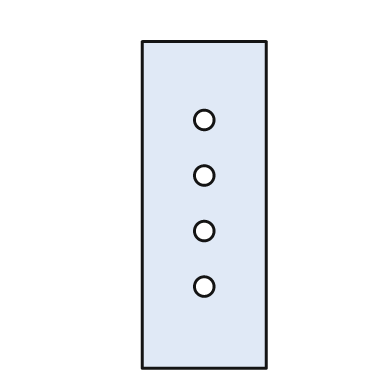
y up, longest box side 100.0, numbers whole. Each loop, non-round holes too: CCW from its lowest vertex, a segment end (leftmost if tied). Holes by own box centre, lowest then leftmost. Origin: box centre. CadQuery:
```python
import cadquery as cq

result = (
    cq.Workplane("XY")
    .moveTo(-19.0, -50.0)
    .lineTo(19.0, -50.0)
    .lineTo(19.0, 50.0)
    .lineTo(-19.0, 50.0)
    .close()
    .moveTo(0.0, -25.0)
    .circle(3.0)
    .moveTo(0.0, -8.0)
    .circle(3.0)
    .moveTo(0.0, 9.0)
    .circle(3.0)
    .moveTo(0.0, 26.0)
    .circle(3.0)
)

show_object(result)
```